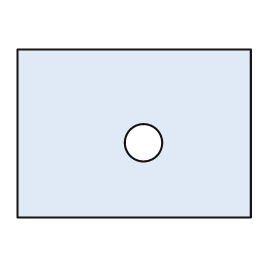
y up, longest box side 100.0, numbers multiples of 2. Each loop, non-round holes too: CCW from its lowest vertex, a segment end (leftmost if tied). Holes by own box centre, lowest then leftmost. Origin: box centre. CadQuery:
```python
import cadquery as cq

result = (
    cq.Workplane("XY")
    .moveTo(-50.0, -36.0)
    .lineTo(50.0, -36.0)
    .lineTo(50.0, 36.0)
    .lineTo(-50.0, 36.0)
    .close()
    .moveTo(4.0, -4.0)
    .circle(8.0)
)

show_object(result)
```